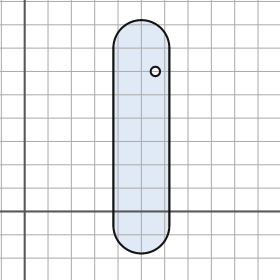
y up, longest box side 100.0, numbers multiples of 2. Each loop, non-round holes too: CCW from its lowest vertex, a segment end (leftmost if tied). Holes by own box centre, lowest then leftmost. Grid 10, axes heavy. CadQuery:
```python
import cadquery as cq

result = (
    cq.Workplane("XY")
    .moveTo(38.0, -6.0)
    .threePointArc((50.0, -18.0), (62.0, -6.0))
    .lineTo(62.0, 70.0)
    .threePointArc((50.0, 82.0), (38.0, 70.0))
    .close()
    .moveTo(56.0, 60.0)
    .circle(2.0)
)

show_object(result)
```